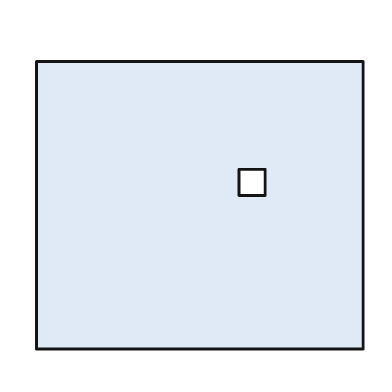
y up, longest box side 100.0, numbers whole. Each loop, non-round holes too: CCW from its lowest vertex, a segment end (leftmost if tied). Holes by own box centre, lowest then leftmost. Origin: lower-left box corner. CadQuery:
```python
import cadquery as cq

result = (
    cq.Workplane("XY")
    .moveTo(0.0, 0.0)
    .lineTo(100.0, 0.0)
    .lineTo(100.0, 88.0)
    .lineTo(0.0, 88.0)
    .close()
    .moveTo(62.0, 47.0)
    .lineTo(70.0, 47.0)
    .lineTo(70.0, 55.0)
    .lineTo(62.0, 55.0)
    .close()
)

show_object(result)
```